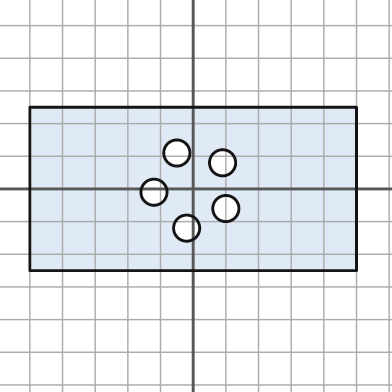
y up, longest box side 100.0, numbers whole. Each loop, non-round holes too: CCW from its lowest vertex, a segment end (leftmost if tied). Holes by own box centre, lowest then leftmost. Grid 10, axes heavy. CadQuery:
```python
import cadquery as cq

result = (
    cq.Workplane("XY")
    .moveTo(-50.0, -25.0)
    .lineTo(50.0, -25.0)
    .lineTo(50.0, 25.0)
    .lineTo(-50.0, 25.0)
    .close()
    .moveTo(-2.0, -12.0)
    .circle(4.0)
    .moveTo(10.0, -6.0)
    .circle(4.0)
    .moveTo(-12.0, -1.0)
    .circle(4.0)
    .moveTo(9.0, 8.0)
    .circle(4.0)
    .moveTo(-5.0, 11.0)
    .circle(4.0)
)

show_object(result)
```